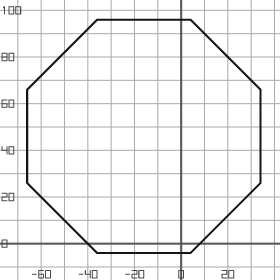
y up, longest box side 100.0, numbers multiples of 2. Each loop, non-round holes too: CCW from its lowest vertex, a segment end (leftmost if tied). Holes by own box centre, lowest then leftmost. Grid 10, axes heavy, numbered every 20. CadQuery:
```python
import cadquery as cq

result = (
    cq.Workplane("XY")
    .moveTo(-36.0, -4.0)
    .lineTo(4.0, -4.0)
    .lineTo(34.0, 26.0)
    .lineTo(34.0, 66.0)
    .lineTo(4.0, 96.0)
    .lineTo(-36.0, 96.0)
    .lineTo(-66.0, 66.0)
    .lineTo(-66.0, 26.0)
    .close()
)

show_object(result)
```